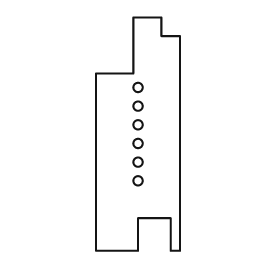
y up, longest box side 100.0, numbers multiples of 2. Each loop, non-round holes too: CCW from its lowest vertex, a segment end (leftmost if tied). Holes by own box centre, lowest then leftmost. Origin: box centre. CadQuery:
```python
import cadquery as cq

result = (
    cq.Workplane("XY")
    .moveTo(-18.0, -50.0)
    .lineTo(0.0, -50.0)
    .lineTo(0.0, -36.0)
    .lineTo(14.0, -36.0)
    .lineTo(14.0, -50.0)
    .lineTo(18.0, -50.0)
    .lineTo(18.0, 42.0)
    .lineTo(10.0, 42.0)
    .lineTo(10.0, 50.0)
    .lineTo(-2.0, 50.0)
    .lineTo(-2.0, 26.0)
    .lineTo(-18.0, 26.0)
    .close()
    .moveTo(0.0, -20.0)
    .circle(2.0)
    .moveTo(0.0, -12.0)
    .circle(2.0)
    .moveTo(0.0, -4.0)
    .circle(2.0)
    .moveTo(0.0, 4.0)
    .circle(2.0)
    .moveTo(0.0, 12.0)
    .circle(2.0)
    .moveTo(0.0, 20.0)
    .circle(2.0)
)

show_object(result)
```